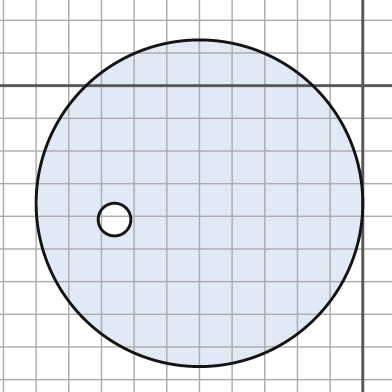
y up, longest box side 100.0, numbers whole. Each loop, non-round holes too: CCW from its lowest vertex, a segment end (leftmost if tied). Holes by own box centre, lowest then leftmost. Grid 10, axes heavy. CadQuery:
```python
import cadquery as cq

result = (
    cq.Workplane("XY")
    .moveTo(-50.0, -36.0)
    .circle(50.0)
    .moveTo(-76.0, -41.0)
    .circle(5.0)
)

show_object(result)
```